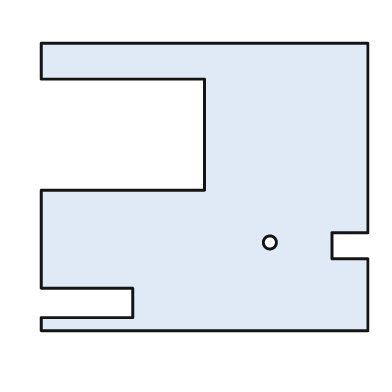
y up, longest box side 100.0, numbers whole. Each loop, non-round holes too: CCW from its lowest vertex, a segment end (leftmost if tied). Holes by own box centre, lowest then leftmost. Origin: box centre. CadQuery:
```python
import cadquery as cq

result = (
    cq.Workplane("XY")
    .moveTo(-50.0, -44.0)
    .lineTo(50.0, -44.0)
    .lineTo(50.0, -22.0)
    .lineTo(39.0, -22.0)
    .lineTo(39.0, -14.0)
    .lineTo(50.0, -14.0)
    .lineTo(50.0, 44.0)
    .lineTo(-50.0, 44.0)
    .lineTo(-50.0, 33.0)
    .lineTo(0.0, 33.0)
    .lineTo(0.0, -1.0)
    .lineTo(-50.0, -1.0)
    .lineTo(-50.0, -31.0)
    .lineTo(-22.0, -31.0)
    .lineTo(-22.0, -40.0)
    .lineTo(-50.0, -40.0)
    .close()
    .moveTo(20.0, -17.0)
    .circle(2.0)
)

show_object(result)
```